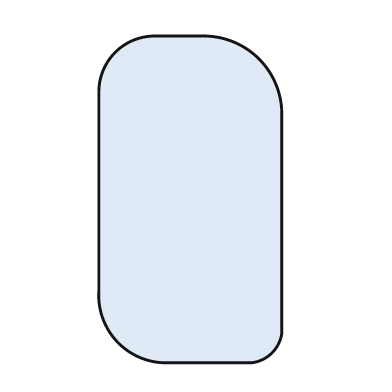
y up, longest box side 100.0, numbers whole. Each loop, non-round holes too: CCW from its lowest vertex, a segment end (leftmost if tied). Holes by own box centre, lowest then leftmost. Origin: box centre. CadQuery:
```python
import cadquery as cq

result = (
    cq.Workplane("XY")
    .moveTo(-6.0, -50.0)
    .lineTo(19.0, -50.0)
    .threePointArc((25.0, -47.0), (28.0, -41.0))
    .lineTo(28.0, 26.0)
    .threePointArc((21.0, 43.0), (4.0, 50.0))
    .lineTo(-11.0, 50.0)
    .threePointArc((-23.0, 45.0), (-28.0, 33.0))
    .lineTo(-28.0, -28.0)
    .threePointArc((-22.0, -44.0), (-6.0, -50.0))
    .close()
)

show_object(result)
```